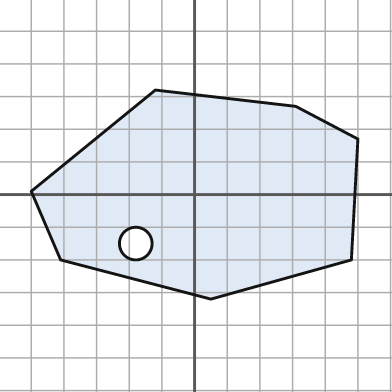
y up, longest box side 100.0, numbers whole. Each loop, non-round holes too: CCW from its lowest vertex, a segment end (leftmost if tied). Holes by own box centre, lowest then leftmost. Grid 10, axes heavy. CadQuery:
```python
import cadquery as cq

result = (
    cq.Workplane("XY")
    .moveTo(5.0, -32.0)
    .lineTo(48.0, -20.0)
    .lineTo(50.0, 17.0)
    .lineTo(31.0, 27.0)
    .lineTo(-12.0, 32.0)
    .lineTo(-50.0, 1.0)
    .lineTo(-41.0, -20.0)
    .close()
    .moveTo(-18.0, -15.0)
    .circle(5.0)
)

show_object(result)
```